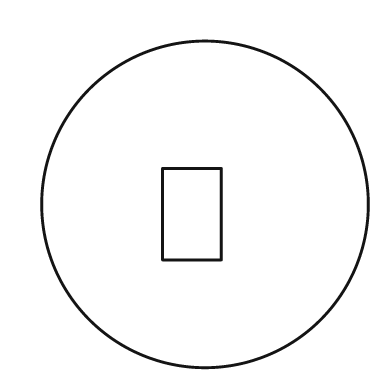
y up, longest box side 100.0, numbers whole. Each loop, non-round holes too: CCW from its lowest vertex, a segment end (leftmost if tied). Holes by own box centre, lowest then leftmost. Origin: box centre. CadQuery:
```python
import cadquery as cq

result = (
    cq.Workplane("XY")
    .moveTo(0.0, 0.0)
    .circle(50.0)
    .moveTo(-13.0, -17.0)
    .lineTo(5.0, -17.0)
    .lineTo(5.0, 11.0)
    .lineTo(-13.0, 11.0)
    .close()
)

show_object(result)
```